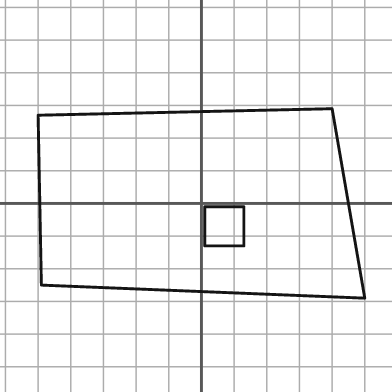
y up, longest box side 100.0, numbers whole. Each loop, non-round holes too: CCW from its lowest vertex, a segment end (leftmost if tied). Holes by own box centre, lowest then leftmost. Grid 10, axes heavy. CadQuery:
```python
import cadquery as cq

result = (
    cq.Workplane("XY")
    .moveTo(50.0, -29.0)
    .lineTo(40.0, 29.0)
    .lineTo(-50.0, 27.0)
    .lineTo(-49.0, -25.0)
    .close()
    .moveTo(1.0, -13.0)
    .lineTo(13.0, -13.0)
    .lineTo(13.0, -1.0)
    .lineTo(1.0, -1.0)
    .close()
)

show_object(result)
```